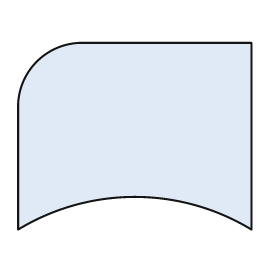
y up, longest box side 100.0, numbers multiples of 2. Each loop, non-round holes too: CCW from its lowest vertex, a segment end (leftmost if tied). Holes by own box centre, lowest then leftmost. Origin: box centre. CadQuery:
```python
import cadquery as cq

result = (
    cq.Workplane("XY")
    .moveTo(-50.0, -40.0)
    .threePointArc((0.0, -26.0), (50.0, -40.0))
    .lineTo(50.0, 40.0)
    .lineTo(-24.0, 40.0)
    .threePointArc((-42.0, 32.0), (-50.0, 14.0))
    .close()
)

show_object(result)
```